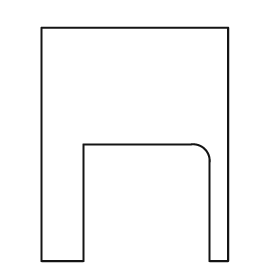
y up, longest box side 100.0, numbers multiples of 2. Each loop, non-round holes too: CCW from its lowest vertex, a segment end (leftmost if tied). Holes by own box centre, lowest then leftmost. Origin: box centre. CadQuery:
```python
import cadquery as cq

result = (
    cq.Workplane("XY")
    .moveTo(-40.0, -50.0)
    .lineTo(-22.0, -50.0)
    .lineTo(-22.0, 0.0)
    .lineTo(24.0, 0.0)
    .threePointArc((30.0, -2.0), (32.0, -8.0))
    .lineTo(32.0, -50.0)
    .lineTo(40.0, -50.0)
    .lineTo(40.0, 50.0)
    .lineTo(-40.0, 50.0)
    .close()
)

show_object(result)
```